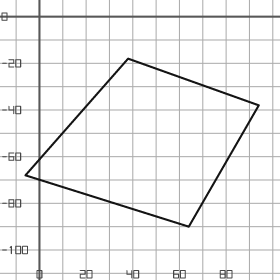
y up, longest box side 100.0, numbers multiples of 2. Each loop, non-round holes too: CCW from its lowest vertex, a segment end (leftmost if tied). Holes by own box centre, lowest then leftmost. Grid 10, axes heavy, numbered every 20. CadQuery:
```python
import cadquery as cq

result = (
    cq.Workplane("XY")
    .moveTo(64.0, -90.0)
    .lineTo(94.0, -38.0)
    .lineTo(38.0, -18.0)
    .lineTo(-6.0, -68.0)
    .close()
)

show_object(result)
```